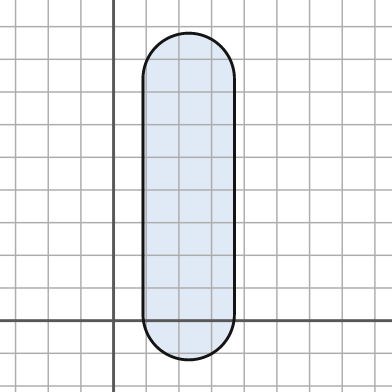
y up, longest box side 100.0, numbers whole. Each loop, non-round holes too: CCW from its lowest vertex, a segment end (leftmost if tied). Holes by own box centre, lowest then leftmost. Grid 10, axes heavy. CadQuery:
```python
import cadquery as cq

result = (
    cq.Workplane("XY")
    .moveTo(9.0, 2.0)
    .threePointArc((23.0, -12.0), (37.0, 2.0))
    .lineTo(37.0, 74.0)
    .threePointArc((23.0, 88.0), (9.0, 74.0))
    .close()
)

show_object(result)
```